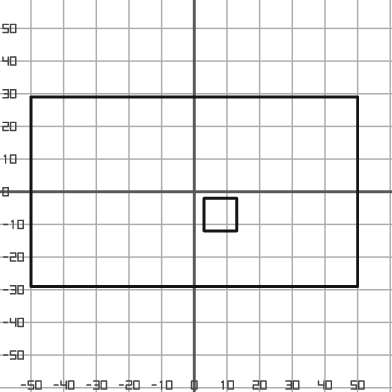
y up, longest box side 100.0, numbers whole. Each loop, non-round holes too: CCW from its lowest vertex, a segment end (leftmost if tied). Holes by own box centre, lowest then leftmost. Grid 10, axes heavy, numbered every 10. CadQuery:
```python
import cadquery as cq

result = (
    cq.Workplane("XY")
    .moveTo(-50.0, -29.0)
    .lineTo(50.0, -29.0)
    .lineTo(50.0, 29.0)
    .lineTo(-50.0, 29.0)
    .close()
    .moveTo(3.0, -12.0)
    .lineTo(13.0, -12.0)
    .lineTo(13.0, -2.0)
    .lineTo(3.0, -2.0)
    .close()
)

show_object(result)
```